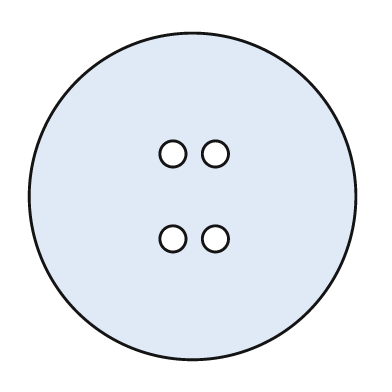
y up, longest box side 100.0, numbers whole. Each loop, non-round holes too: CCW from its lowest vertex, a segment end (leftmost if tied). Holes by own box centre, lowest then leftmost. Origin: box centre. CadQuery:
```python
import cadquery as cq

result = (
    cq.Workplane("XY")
    .moveTo(0.0, 0.0)
    .circle(50.0)
    .moveTo(-6.0, -13.0)
    .circle(4.0)
    .moveTo(7.0, -13.0)
    .circle(4.0)
    .moveTo(-6.0, 13.0)
    .circle(4.0)
    .moveTo(7.0, 13.0)
    .circle(4.0)
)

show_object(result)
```